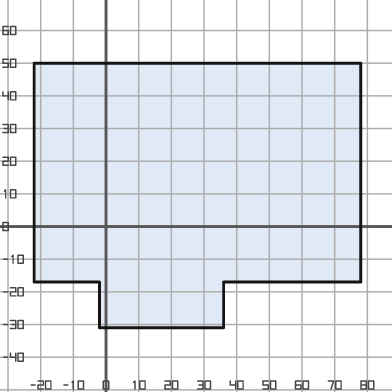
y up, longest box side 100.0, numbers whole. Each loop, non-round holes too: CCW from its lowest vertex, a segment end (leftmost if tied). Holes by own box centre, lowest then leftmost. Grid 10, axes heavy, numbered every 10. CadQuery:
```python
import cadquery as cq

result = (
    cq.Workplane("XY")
    .moveTo(-2.0, -31.0)
    .lineTo(36.0, -31.0)
    .lineTo(36.0, -17.0)
    .lineTo(78.0, -17.0)
    .lineTo(78.0, 50.0)
    .lineTo(-22.0, 50.0)
    .lineTo(-22.0, -17.0)
    .lineTo(-2.0, -17.0)
    .close()
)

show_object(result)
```